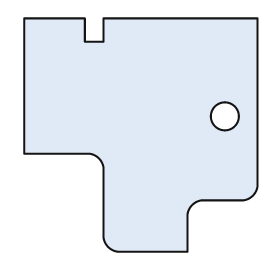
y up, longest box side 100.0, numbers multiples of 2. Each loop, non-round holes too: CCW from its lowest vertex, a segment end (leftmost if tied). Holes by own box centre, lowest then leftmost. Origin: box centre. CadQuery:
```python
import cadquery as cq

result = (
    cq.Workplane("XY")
    .moveTo(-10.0, -50.0)
    .lineTo(20.0, -50.0)
    .lineTo(20.0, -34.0)
    .threePointArc((22.0, -30.0), (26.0, -28.0))
    .lineTo(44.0, -28.0)
    .threePointArc((48.0, -26.0), (50.0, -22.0))
    .lineTo(50.0, 50.0)
    .lineTo(-16.0, 50.0)
    .lineTo(-16.0, 40.0)
    .lineTo(-24.0, 40.0)
    .lineTo(-24.0, 50.0)
    .lineTo(-50.0, 50.0)
    .lineTo(-50.0, -8.0)
    .lineTo(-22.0, -8.0)
    .threePointArc((-18.0, -10.0), (-16.0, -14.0))
    .lineTo(-16.0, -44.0)
    .threePointArc((-14.0, -48.0), (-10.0, -50.0))
    .close()
    .moveTo(36.0, 8.0)
    .circle(6.0)
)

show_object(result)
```